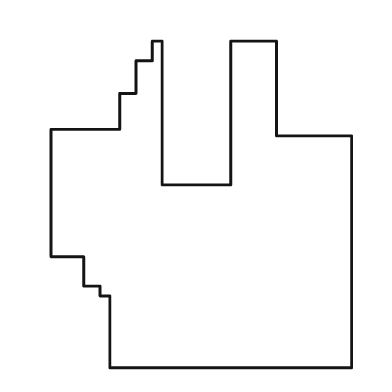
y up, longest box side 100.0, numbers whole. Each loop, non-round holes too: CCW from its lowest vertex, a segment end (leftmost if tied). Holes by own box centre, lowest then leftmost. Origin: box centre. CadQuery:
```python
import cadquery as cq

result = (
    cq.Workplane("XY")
    .moveTo(-28.0, -50.0)
    .lineTo(46.0, -50.0)
    .lineTo(46.0, 21.0)
    .lineTo(23.0, 21.0)
    .lineTo(23.0, 50.0)
    .lineTo(9.0, 50.0)
    .lineTo(9.0, 6.0)
    .lineTo(-12.0, 6.0)
    .lineTo(-12.0, 50.0)
    .lineTo(-15.0, 50.0)
    .lineTo(-15.0, 44.0)
    .lineTo(-20.0, 44.0)
    .lineTo(-20.0, 34.0)
    .lineTo(-25.0, 34.0)
    .lineTo(-25.0, 23.0)
    .lineTo(-46.0, 23.0)
    .lineTo(-46.0, -16.0)
    .lineTo(-36.0, -16.0)
    .lineTo(-36.0, -25.0)
    .lineTo(-31.0, -25.0)
    .lineTo(-31.0, -28.0)
    .lineTo(-28.0, -28.0)
    .close()
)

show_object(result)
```